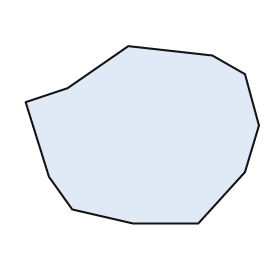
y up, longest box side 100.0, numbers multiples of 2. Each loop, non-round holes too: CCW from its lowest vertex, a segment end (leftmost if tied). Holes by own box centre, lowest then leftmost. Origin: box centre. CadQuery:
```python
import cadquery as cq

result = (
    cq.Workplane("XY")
    .moveTo(-4.0, -38.0)
    .lineTo(24.0, -38.0)
    .lineTo(44.0, -16.0)
    .lineTo(50.0, 4.0)
    .lineTo(44.0, 26.0)
    .lineTo(30.0, 34.0)
    .lineTo(-6.0, 38.0)
    .lineTo(-32.0, 20.0)
    .lineTo(-50.0, 14.0)
    .lineTo(-40.0, -18.0)
    .lineTo(-30.0, -32.0)
    .close()
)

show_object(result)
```